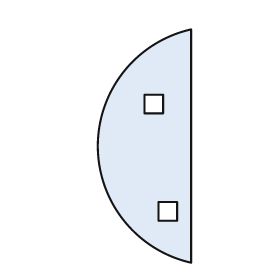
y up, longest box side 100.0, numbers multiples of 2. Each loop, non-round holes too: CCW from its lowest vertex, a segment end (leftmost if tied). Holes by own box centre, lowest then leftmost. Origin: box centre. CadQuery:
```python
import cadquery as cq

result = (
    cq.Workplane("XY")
    .moveTo(20.0, -50.0)
    .lineTo(20.0, 50.0)
    .threePointArc((-20.0, 0.0), (20.0, -50.0))
    .close()
    .moveTo(6.0, -32.0)
    .lineTo(14.0, -32.0)
    .lineTo(14.0, -24.0)
    .lineTo(6.0, -24.0)
    .close()
    .moveTo(0.0, 14.0)
    .lineTo(8.0, 14.0)
    .lineTo(8.0, 22.0)
    .lineTo(0.0, 22.0)
    .close()
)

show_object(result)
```